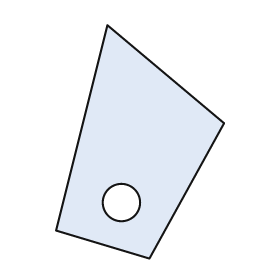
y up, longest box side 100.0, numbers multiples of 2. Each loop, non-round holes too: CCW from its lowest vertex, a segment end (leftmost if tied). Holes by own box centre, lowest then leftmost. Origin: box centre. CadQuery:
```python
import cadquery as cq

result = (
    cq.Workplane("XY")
    .moveTo(4.0, -50.0)
    .lineTo(36.0, 8.0)
    .lineTo(-14.0, 50.0)
    .lineTo(-36.0, -38.0)
    .close()
    .moveTo(-8.0, -26.0)
    .circle(8.0)
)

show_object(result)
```